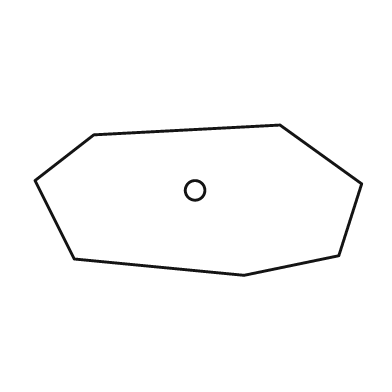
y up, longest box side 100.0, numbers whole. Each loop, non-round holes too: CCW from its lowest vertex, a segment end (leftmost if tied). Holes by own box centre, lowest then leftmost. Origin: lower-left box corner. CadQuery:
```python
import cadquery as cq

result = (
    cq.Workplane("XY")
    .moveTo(64.0, 0.0)
    .lineTo(93.0, 6.0)
    .lineTo(100.0, 28.0)
    .lineTo(75.0, 46.0)
    .lineTo(18.0, 43.0)
    .lineTo(0.0, 29.0)
    .lineTo(12.0, 5.0)
    .close()
    .moveTo(49.0, 26.0)
    .circle(3.0)
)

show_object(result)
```